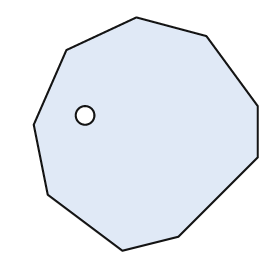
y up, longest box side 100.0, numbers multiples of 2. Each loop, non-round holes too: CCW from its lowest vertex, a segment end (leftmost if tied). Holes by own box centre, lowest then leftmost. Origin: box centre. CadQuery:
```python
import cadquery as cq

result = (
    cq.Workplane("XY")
    .moveTo(-10.0, -50.0)
    .lineTo(14.0, -44.0)
    .lineTo(48.0, -10.0)
    .lineTo(48.0, 12.0)
    .lineTo(26.0, 42.0)
    .lineTo(-4.0, 50.0)
    .lineTo(-34.0, 36.0)
    .lineTo(-48.0, 4.0)
    .lineTo(-42.0, -26.0)
    .close()
    .moveTo(-26.0, 8.0)
    .circle(4.0)
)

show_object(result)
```